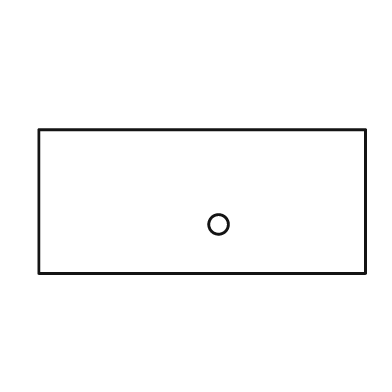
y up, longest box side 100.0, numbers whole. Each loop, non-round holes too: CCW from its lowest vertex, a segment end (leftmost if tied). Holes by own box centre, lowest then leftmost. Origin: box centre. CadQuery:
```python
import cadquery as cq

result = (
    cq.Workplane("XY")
    .moveTo(-50.0, -22.0)
    .lineTo(50.0, -22.0)
    .lineTo(50.0, 22.0)
    .lineTo(-50.0, 22.0)
    .close()
    .moveTo(5.0, -7.0)
    .circle(3.0)
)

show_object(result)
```